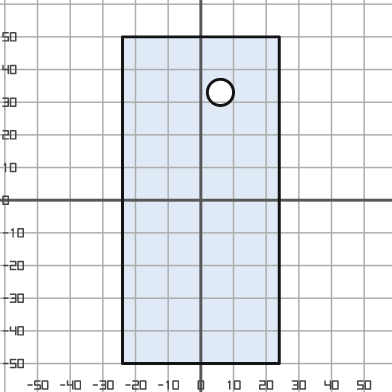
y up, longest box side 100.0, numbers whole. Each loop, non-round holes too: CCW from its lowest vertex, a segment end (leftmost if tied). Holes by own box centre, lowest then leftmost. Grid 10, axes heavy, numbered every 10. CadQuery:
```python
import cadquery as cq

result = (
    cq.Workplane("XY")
    .moveTo(-24.0, -50.0)
    .lineTo(24.0, -50.0)
    .lineTo(24.0, 50.0)
    .lineTo(-24.0, 50.0)
    .close()
    .moveTo(6.0, 33.0)
    .circle(4.0)
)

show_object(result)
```